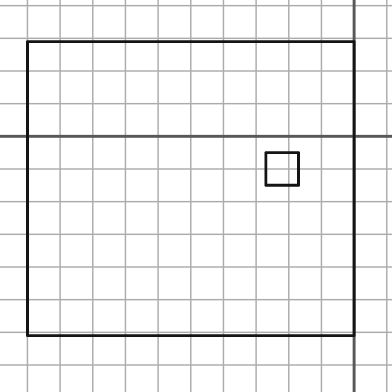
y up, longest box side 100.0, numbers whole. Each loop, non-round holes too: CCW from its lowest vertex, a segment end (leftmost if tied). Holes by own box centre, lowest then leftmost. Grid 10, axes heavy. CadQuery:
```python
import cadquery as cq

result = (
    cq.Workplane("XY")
    .moveTo(-100.0, -61.0)
    .lineTo(0.0, -61.0)
    .lineTo(0.0, 29.0)
    .lineTo(-100.0, 29.0)
    .close()
    .moveTo(-27.0, -15.0)
    .lineTo(-17.0, -15.0)
    .lineTo(-17.0, -5.0)
    .lineTo(-27.0, -5.0)
    .close()
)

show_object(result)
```